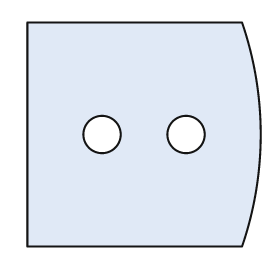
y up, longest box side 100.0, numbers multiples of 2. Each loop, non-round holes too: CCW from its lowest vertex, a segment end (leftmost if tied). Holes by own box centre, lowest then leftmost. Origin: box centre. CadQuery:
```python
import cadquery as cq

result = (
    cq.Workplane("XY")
    .moveTo(-50.0, -48.0)
    .lineTo(42.0, -48.0)
    .threePointArc((50.0, 0.0), (42.0, 48.0))
    .lineTo(-50.0, 48.0)
    .close()
    .moveTo(-18.0, 0.0)
    .circle(8.0)
    .moveTo(18.0, 0.0)
    .circle(8.0)
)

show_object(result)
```